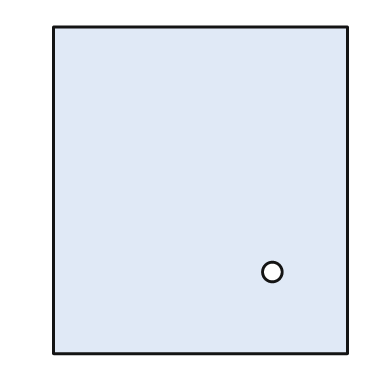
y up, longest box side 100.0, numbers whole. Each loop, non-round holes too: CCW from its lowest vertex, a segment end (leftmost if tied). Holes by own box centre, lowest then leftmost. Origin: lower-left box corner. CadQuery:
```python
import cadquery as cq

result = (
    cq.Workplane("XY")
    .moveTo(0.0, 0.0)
    .lineTo(90.0, 0.0)
    .lineTo(90.0, 100.0)
    .lineTo(0.0, 100.0)
    .close()
    .moveTo(67.0, 25.0)
    .circle(3.0)
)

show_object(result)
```